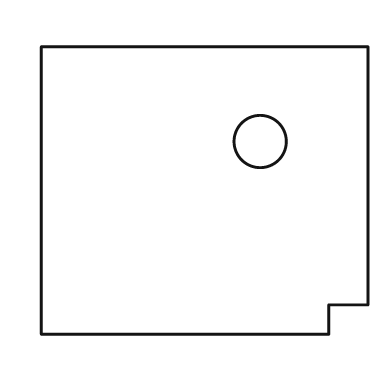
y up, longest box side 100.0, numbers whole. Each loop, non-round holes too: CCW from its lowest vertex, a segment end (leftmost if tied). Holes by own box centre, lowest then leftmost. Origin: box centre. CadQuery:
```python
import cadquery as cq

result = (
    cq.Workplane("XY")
    .moveTo(-50.0, -44.0)
    .lineTo(38.0, -44.0)
    .lineTo(38.0, -35.0)
    .lineTo(50.0, -35.0)
    .lineTo(50.0, 44.0)
    .lineTo(-50.0, 44.0)
    .close()
    .moveTo(17.0, 15.0)
    .circle(8.0)
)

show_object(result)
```